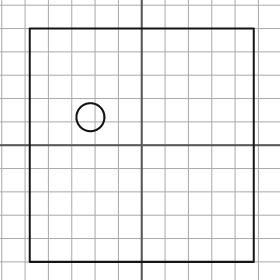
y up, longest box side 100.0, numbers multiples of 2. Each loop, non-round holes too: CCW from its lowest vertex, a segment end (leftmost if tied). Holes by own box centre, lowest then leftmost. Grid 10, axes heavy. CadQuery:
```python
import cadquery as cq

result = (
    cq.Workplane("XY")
    .moveTo(-48.0, -50.0)
    .lineTo(48.0, -50.0)
    .lineTo(48.0, 50.0)
    .lineTo(-48.0, 50.0)
    .close()
    .moveTo(-22.0, 12.0)
    .circle(6.0)
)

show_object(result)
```